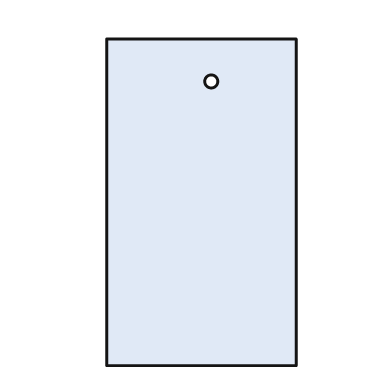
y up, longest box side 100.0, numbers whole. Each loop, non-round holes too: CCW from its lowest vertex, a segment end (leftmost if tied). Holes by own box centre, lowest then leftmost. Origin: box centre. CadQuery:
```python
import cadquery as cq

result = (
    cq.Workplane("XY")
    .moveTo(-29.0, -50.0)
    .lineTo(29.0, -50.0)
    .lineTo(29.0, 50.0)
    .lineTo(-29.0, 50.0)
    .close()
    .moveTo(3.0, 37.0)
    .circle(2.0)
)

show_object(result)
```